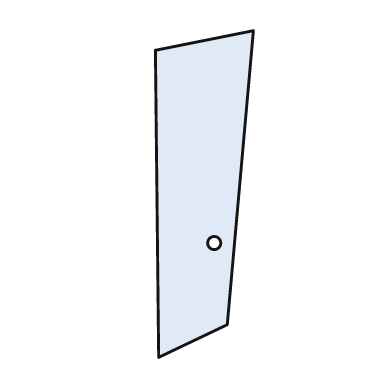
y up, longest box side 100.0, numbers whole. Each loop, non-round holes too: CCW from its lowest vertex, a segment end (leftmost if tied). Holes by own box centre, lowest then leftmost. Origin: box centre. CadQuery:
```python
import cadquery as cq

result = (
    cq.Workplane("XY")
    .moveTo(-14.0, -50.0)
    .lineTo(7.0, -40.0)
    .lineTo(15.0, 50.0)
    .lineTo(-15.0, 44.0)
    .close()
    .moveTo(3.0, -15.0)
    .circle(2.0)
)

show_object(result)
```